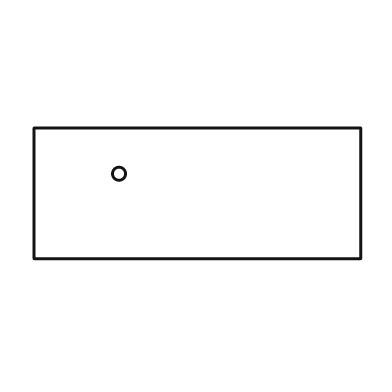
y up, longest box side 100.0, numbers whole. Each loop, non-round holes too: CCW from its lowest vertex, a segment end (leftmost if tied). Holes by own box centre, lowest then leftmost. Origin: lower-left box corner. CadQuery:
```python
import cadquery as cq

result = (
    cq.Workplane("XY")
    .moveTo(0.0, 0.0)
    .lineTo(100.0, 0.0)
    .lineTo(100.0, 40.0)
    .lineTo(0.0, 40.0)
    .close()
    .moveTo(26.0, 26.0)
    .circle(2.0)
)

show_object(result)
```